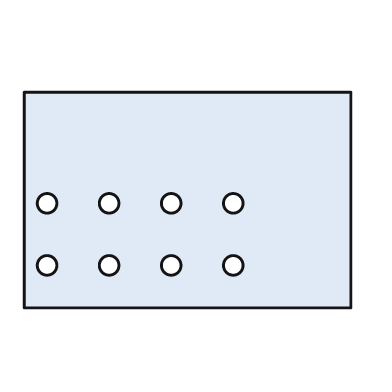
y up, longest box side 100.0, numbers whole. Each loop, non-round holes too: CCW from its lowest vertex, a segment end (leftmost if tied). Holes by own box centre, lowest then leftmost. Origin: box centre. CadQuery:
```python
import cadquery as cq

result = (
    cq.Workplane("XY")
    .moveTo(-50.0, -33.0)
    .lineTo(50.0, -33.0)
    .lineTo(50.0, 33.0)
    .lineTo(-50.0, 33.0)
    .close()
    .moveTo(-43.0, -20.0)
    .circle(3.0)
    .moveTo(-24.0, -20.0)
    .circle(3.0)
    .moveTo(-5.0, -20.0)
    .circle(3.0)
    .moveTo(14.0, -20.0)
    .circle(3.0)
    .moveTo(-43.0, -1.0)
    .circle(3.0)
    .moveTo(-24.0, -1.0)
    .circle(3.0)
    .moveTo(-5.0, -1.0)
    .circle(3.0)
    .moveTo(14.0, -1.0)
    .circle(3.0)
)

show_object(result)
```